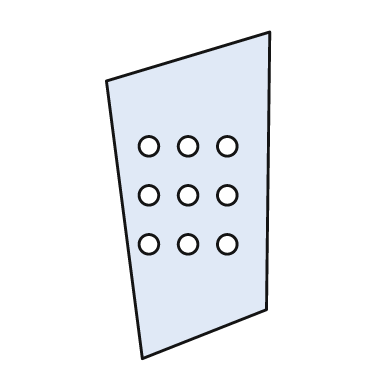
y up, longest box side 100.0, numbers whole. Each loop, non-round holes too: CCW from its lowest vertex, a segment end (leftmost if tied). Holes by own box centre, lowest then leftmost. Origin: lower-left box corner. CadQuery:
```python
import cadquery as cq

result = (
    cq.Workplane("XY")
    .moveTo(11.0, 0.0)
    .lineTo(49.0, 15.0)
    .lineTo(50.0, 100.0)
    .lineTo(0.0, 85.0)
    .close()
    .moveTo(13.0, 35.0)
    .circle(3.0)
    .moveTo(25.0, 35.0)
    .circle(3.0)
    .moveTo(37.0, 35.0)
    .circle(3.0)
    .moveTo(13.0, 50.0)
    .circle(3.0)
    .moveTo(25.0, 50.0)
    .circle(3.0)
    .moveTo(37.0, 50.0)
    .circle(3.0)
    .moveTo(13.0, 65.0)
    .circle(3.0)
    .moveTo(25.0, 65.0)
    .circle(3.0)
    .moveTo(37.0, 65.0)
    .circle(3.0)
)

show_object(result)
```